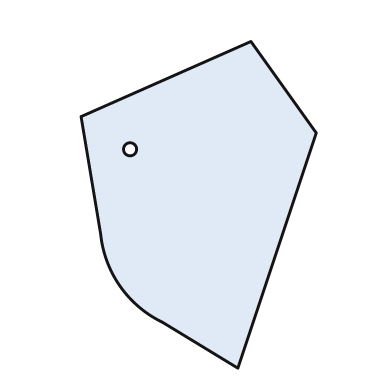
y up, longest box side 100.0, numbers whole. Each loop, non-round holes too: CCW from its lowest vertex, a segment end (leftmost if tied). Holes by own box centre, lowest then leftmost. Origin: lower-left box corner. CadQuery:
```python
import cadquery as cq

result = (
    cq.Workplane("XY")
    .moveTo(48.0, 0.0)
    .lineTo(72.0, 72.0)
    .lineTo(52.0, 100.0)
    .lineTo(0.0, 77.0)
    .lineTo(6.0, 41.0)
    .threePointArc((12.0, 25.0), (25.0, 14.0))
    .close()
    .moveTo(15.0, 67.0)
    .circle(2.0)
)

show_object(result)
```